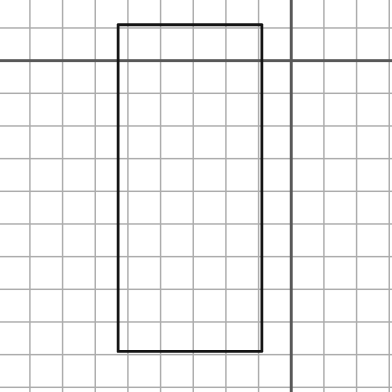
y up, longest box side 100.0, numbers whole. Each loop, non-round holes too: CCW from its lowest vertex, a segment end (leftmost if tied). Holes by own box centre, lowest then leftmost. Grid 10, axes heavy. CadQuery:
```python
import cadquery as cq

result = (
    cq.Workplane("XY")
    .moveTo(-53.0, -89.0)
    .lineTo(-9.0, -89.0)
    .lineTo(-9.0, 11.0)
    .lineTo(-53.0, 11.0)
    .close()
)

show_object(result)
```